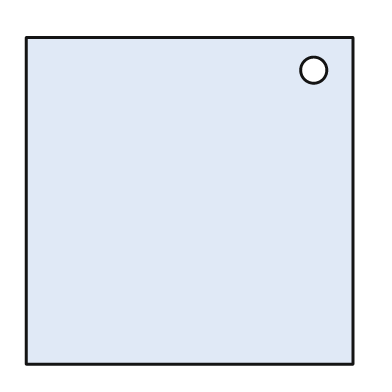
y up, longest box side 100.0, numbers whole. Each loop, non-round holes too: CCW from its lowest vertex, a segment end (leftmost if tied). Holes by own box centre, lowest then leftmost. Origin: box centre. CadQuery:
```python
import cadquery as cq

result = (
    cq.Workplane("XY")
    .moveTo(-50.0, -50.0)
    .lineTo(50.0, -50.0)
    .lineTo(50.0, 50.0)
    .lineTo(-50.0, 50.0)
    .close()
    .moveTo(38.0, 40.0)
    .circle(4.0)
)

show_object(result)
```